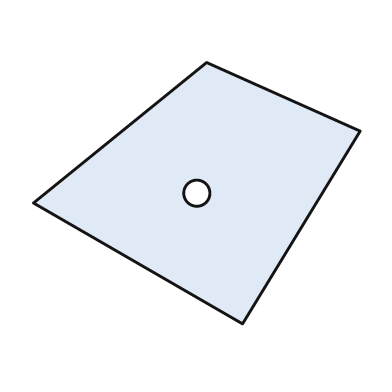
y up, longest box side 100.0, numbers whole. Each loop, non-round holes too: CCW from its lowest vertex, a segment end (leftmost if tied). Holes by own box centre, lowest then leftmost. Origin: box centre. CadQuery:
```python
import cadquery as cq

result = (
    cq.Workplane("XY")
    .moveTo(14.0, -40.0)
    .lineTo(50.0, 19.0)
    .lineTo(3.0, 40.0)
    .lineTo(-50.0, -3.0)
    .close()
    .moveTo(0.0, 0.0)
    .circle(4.0)
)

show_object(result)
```